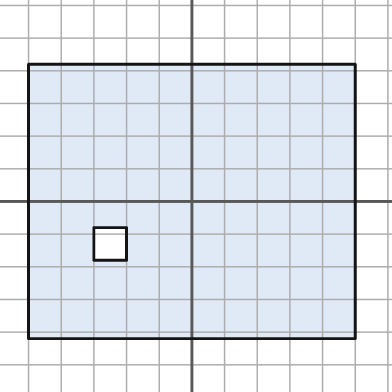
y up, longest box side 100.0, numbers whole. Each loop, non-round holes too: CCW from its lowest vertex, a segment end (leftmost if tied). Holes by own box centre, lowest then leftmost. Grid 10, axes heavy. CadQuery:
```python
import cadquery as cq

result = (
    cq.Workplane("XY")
    .moveTo(-50.0, -42.0)
    .lineTo(50.0, -42.0)
    .lineTo(50.0, 42.0)
    .lineTo(-50.0, 42.0)
    .close()
    .moveTo(-30.0, -18.0)
    .lineTo(-20.0, -18.0)
    .lineTo(-20.0, -8.0)
    .lineTo(-30.0, -8.0)
    .close()
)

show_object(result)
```